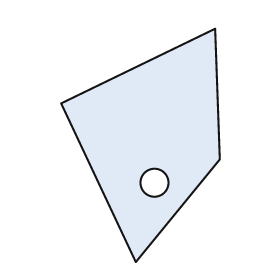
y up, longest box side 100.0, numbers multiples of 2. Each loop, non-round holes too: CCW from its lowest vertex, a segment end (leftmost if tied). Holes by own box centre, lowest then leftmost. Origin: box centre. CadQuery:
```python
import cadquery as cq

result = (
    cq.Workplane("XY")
    .moveTo(-2.0, -50.0)
    .lineTo(34.0, -6.0)
    .lineTo(32.0, 50.0)
    .lineTo(-34.0, 18.0)
    .close()
    .moveTo(6.0, -16.0)
    .circle(6.0)
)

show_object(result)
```